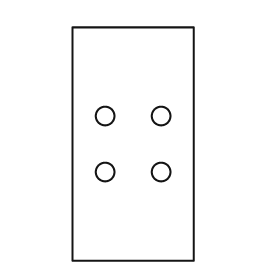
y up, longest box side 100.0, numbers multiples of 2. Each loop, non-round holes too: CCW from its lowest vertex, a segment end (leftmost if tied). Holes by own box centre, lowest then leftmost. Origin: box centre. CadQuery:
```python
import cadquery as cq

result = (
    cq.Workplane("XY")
    .moveTo(-26.0, -50.0)
    .lineTo(26.0, -50.0)
    .lineTo(26.0, 50.0)
    .lineTo(-26.0, 50.0)
    .close()
    .moveTo(-12.0, -12.0)
    .circle(4.0)
    .moveTo(12.0, -12.0)
    .circle(4.0)
    .moveTo(-12.0, 12.0)
    .circle(4.0)
    .moveTo(12.0, 12.0)
    .circle(4.0)
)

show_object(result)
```